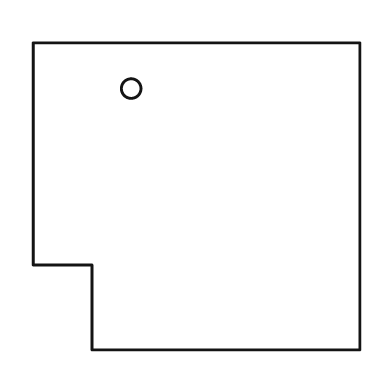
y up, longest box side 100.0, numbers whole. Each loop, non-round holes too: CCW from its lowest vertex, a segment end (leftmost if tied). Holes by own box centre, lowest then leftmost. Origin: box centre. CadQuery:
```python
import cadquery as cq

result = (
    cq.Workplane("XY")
    .moveTo(-32.0, -47.0)
    .lineTo(50.0, -47.0)
    .lineTo(50.0, 47.0)
    .lineTo(-50.0, 47.0)
    .lineTo(-50.0, -21.0)
    .lineTo(-32.0, -21.0)
    .close()
    .moveTo(-20.0, 33.0)
    .circle(3.0)
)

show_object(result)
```